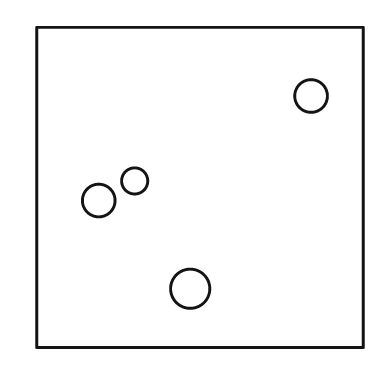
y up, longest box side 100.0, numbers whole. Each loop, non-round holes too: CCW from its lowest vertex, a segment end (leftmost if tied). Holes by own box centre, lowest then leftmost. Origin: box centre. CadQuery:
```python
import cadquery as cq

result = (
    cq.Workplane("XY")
    .moveTo(-50.0, -49.0)
    .lineTo(50.0, -49.0)
    .lineTo(50.0, 49.0)
    .lineTo(-50.0, 49.0)
    .close()
    .moveTo(-3.0, -31.0)
    .circle(6.0)
    .moveTo(-31.0, -4.0)
    .circle(5.0)
    .moveTo(-20.0, 2.0)
    .circle(4.0)
    .moveTo(34.0, 28.0)
    .circle(5.0)
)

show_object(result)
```